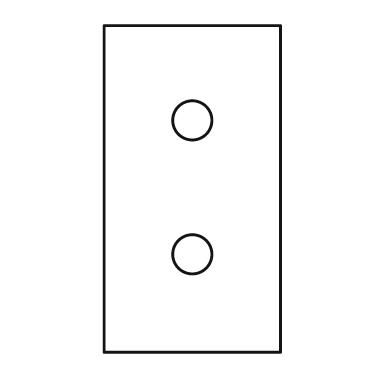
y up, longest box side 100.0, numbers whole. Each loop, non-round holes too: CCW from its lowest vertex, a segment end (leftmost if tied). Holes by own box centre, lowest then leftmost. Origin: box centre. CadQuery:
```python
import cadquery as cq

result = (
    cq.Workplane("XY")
    .moveTo(-27.0, -50.0)
    .lineTo(27.0, -50.0)
    .lineTo(27.0, 50.0)
    .lineTo(-27.0, 50.0)
    .close()
    .moveTo(0.0, -20.0)
    .circle(6.0)
    .moveTo(0.0, 21.0)
    .circle(6.0)
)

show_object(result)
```